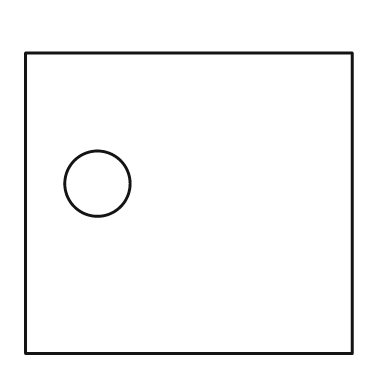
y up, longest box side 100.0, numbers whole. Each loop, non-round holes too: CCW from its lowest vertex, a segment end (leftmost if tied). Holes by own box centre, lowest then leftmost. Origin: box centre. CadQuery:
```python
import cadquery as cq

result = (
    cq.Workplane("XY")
    .moveTo(-50.0, -46.0)
    .lineTo(50.0, -46.0)
    .lineTo(50.0, 46.0)
    .lineTo(-50.0, 46.0)
    .close()
    .moveTo(-28.0, 6.0)
    .circle(10.0)
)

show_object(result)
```